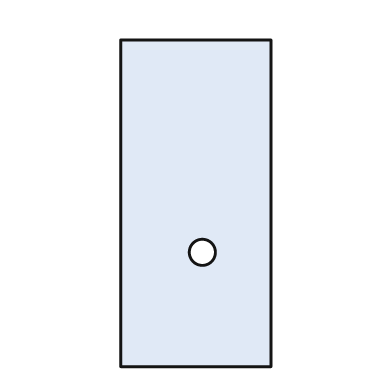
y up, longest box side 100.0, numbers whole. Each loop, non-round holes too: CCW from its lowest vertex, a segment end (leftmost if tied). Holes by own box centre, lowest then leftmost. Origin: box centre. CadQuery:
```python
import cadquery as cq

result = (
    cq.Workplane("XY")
    .moveTo(-23.0, -50.0)
    .lineTo(23.0, -50.0)
    .lineTo(23.0, 50.0)
    .lineTo(-23.0, 50.0)
    .close()
    .moveTo(2.0, -15.0)
    .circle(4.0)
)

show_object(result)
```